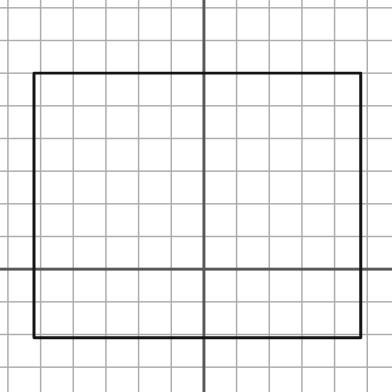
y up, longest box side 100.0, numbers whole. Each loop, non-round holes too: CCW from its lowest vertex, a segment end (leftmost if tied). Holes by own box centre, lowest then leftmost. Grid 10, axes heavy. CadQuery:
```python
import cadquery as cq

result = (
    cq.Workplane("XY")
    .moveTo(-52.0, -21.0)
    .lineTo(48.0, -21.0)
    .lineTo(48.0, 60.0)
    .lineTo(-52.0, 60.0)
    .close()
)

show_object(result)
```